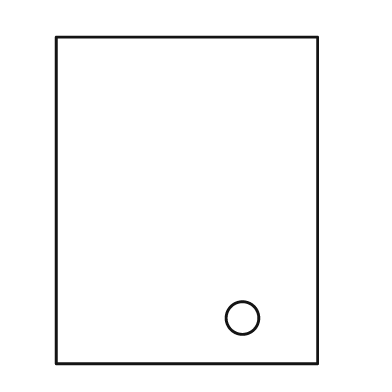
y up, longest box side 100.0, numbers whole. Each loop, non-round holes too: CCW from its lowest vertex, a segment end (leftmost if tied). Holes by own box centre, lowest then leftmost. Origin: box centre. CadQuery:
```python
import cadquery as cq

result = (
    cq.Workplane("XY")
    .moveTo(-40.0, -50.0)
    .lineTo(40.0, -50.0)
    .lineTo(40.0, 50.0)
    .lineTo(-40.0, 50.0)
    .close()
    .moveTo(17.0, -36.0)
    .circle(5.0)
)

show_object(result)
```